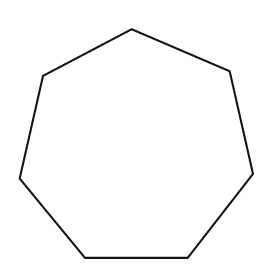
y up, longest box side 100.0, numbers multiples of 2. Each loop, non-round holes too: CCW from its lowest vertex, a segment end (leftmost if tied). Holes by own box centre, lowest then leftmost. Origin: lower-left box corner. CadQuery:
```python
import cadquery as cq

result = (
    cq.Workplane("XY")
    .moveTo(28.0, 0.0)
    .lineTo(72.0, 0.0)
    .lineTo(100.0, 36.0)
    .lineTo(90.0, 80.0)
    .lineTo(48.0, 98.0)
    .lineTo(10.0, 78.0)
    .lineTo(0.0, 34.0)
    .close()
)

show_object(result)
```